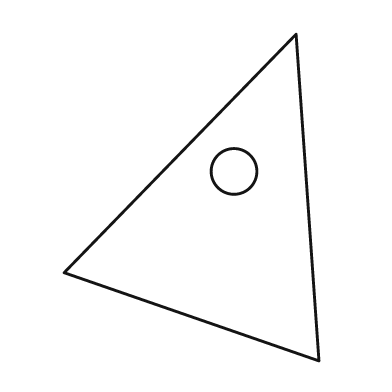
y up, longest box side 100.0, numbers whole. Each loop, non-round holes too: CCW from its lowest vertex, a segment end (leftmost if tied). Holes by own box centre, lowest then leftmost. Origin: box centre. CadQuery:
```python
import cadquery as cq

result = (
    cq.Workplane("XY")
    .moveTo(39.0, -50.0)
    .lineTo(32.0, 50.0)
    .lineTo(-39.0, -23.0)
    .close()
    .moveTo(13.0, 8.0)
    .circle(7.0)
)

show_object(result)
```